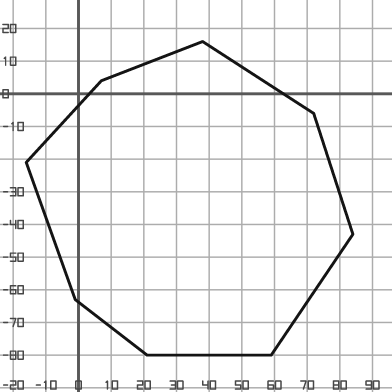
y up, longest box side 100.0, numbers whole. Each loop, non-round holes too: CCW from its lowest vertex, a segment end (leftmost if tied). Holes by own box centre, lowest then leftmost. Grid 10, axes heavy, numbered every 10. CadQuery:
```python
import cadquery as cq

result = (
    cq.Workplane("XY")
    .moveTo(21.0, -80.0)
    .lineTo(59.0, -80.0)
    .lineTo(84.0, -43.0)
    .lineTo(72.0, -6.0)
    .lineTo(38.0, 16.0)
    .lineTo(7.0, 4.0)
    .lineTo(-16.0, -21.0)
    .lineTo(-1.0, -63.0)
    .close()
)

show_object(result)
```